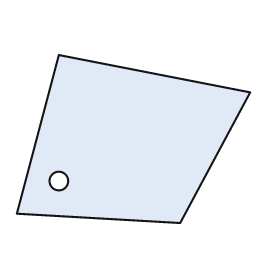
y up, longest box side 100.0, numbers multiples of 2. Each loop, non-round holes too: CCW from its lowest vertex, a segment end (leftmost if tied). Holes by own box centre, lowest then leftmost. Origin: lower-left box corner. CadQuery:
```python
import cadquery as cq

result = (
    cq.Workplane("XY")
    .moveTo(70.0, 0.0)
    .lineTo(100.0, 56.0)
    .lineTo(18.0, 72.0)
    .lineTo(0.0, 4.0)
    .close()
    .moveTo(18.0, 18.0)
    .circle(4.0)
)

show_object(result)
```